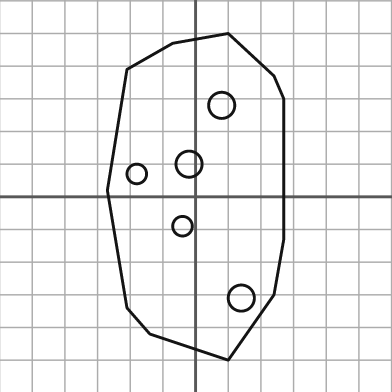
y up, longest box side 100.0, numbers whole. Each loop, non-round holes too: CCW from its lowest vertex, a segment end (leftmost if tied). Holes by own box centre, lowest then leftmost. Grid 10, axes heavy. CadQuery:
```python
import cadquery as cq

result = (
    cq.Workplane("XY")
    .moveTo(10.0, -50.0)
    .lineTo(24.0, -30.0)
    .lineTo(27.0, -13.0)
    .lineTo(27.0, 30.0)
    .lineTo(24.0, 37.0)
    .lineTo(10.0, 50.0)
    .lineTo(-7.0, 47.0)
    .lineTo(-21.0, 39.0)
    .lineTo(-27.0, 2.0)
    .lineTo(-21.0, -34.0)
    .lineTo(-14.0, -42.0)
    .close()
    .moveTo(14.0, -31.0)
    .circle(4.0)
    .moveTo(-4.0, -9.0)
    .circle(3.0)
    .moveTo(-18.0, 7.0)
    .circle(3.0)
    .moveTo(-2.0, 10.0)
    .circle(4.0)
    .moveTo(8.0, 28.0)
    .circle(4.0)
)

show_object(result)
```